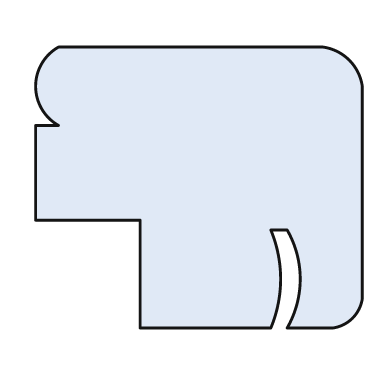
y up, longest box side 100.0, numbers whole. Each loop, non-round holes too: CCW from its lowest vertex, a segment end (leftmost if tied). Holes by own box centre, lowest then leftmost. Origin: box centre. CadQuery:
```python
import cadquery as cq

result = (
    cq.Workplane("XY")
    .moveTo(-18.0, -43.0)
    .lineTo(22.0, -43.0)
    .threePointArc((25.0, -28.0), (22.0, -13.0))
    .lineTo(27.0, -13.0)
    .threePointArc((31.0, -28.0), (27.0, -43.0))
    .lineTo(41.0, -43.0)
    .threePointArc((47.0, -40.0), (50.0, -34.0))
    .lineTo(50.0, 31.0)
    .threePointArc((46.0, 39.0), (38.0, 43.0))
    .lineTo(-43.0, 43.0)
    .threePointArc((-50.0, 31.0), (-43.0, 19.0))
    .lineTo(-50.0, 19.0)
    .lineTo(-50.0, -10.0)
    .lineTo(-18.0, -10.0)
    .close()
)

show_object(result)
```